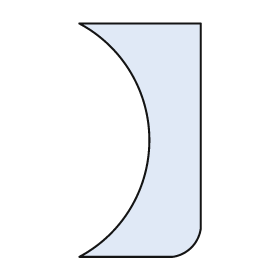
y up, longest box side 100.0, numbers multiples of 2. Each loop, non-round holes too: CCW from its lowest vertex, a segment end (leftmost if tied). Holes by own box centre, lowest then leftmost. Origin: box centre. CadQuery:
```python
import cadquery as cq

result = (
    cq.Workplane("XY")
    .moveTo(-26.0, -50.0)
    .lineTo(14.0, -50.0)
    .threePointArc((22.0, -46.0), (26.0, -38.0))
    .lineTo(26.0, 50.0)
    .lineTo(-26.0, 50.0)
    .threePointArc((4.0, 0.0), (-26.0, -50.0))
    .close()
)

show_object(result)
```